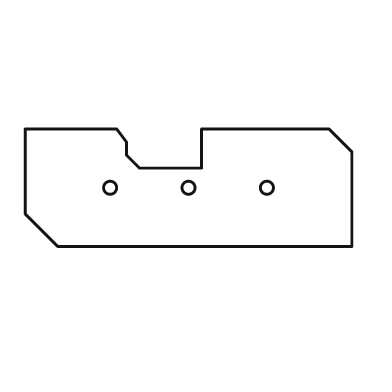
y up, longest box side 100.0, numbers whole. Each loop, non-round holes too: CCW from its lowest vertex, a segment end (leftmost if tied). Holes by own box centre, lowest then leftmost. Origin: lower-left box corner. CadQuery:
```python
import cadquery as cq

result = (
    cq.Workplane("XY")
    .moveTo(10.0, 0.0)
    .lineTo(100.0, 0.0)
    .lineTo(100.0, 29.0)
    .lineTo(93.0, 36.0)
    .lineTo(54.0, 36.0)
    .lineTo(54.0, 24.0)
    .lineTo(35.0, 24.0)
    .lineTo(31.0, 28.0)
    .lineTo(31.0, 32.0)
    .lineTo(28.0, 36.0)
    .lineTo(0.0, 36.0)
    .lineTo(0.0, 10.0)
    .close()
    .moveTo(26.0, 18.0)
    .circle(2.0)
    .moveTo(50.0, 18.0)
    .circle(2.0)
    .moveTo(74.0, 18.0)
    .circle(2.0)
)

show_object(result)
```